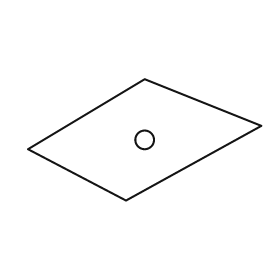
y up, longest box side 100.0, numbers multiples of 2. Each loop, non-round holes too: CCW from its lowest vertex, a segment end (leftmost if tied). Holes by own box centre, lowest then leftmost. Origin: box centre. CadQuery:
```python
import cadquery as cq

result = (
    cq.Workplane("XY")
    .moveTo(-8.0, -26.0)
    .lineTo(50.0, 6.0)
    .lineTo(0.0, 26.0)
    .lineTo(-50.0, -4.0)
    .close()
    .moveTo(0.0, 0.0)
    .circle(4.0)
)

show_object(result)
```